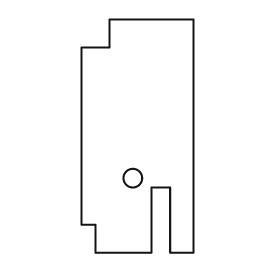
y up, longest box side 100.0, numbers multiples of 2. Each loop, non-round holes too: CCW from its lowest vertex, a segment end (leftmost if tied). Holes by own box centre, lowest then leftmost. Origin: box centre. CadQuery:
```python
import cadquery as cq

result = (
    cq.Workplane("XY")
    .moveTo(-18.0, -50.0)
    .lineTo(6.0, -50.0)
    .lineTo(6.0, -22.0)
    .lineTo(14.0, -22.0)
    .lineTo(14.0, -50.0)
    .lineTo(24.0, -50.0)
    .lineTo(24.0, 50.0)
    .lineTo(-12.0, 50.0)
    .lineTo(-12.0, 38.0)
    .lineTo(-24.0, 38.0)
    .lineTo(-24.0, -38.0)
    .lineTo(-18.0, -38.0)
    .close()
    .moveTo(-2.0, -18.0)
    .circle(4.0)
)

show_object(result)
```